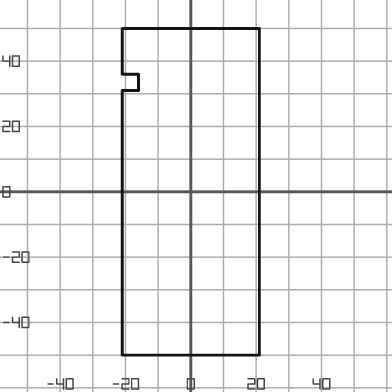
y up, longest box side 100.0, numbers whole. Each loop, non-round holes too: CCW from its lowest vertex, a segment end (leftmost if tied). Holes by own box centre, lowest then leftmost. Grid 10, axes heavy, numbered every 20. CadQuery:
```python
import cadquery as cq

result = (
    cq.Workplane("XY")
    .moveTo(-21.0, -50.0)
    .lineTo(21.0, -50.0)
    .lineTo(21.0, 50.0)
    .lineTo(-21.0, 50.0)
    .lineTo(-21.0, 36.0)
    .lineTo(-16.0, 36.0)
    .lineTo(-16.0, 31.0)
    .lineTo(-21.0, 31.0)
    .close()
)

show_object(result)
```